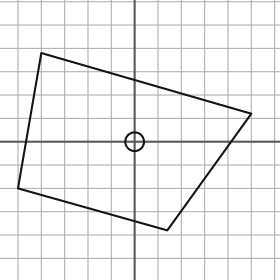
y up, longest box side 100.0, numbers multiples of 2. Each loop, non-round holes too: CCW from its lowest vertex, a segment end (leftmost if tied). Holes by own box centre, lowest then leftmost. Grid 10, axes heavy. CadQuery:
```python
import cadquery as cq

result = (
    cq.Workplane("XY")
    .moveTo(14.0, -38.0)
    .lineTo(50.0, 12.0)
    .lineTo(-40.0, 38.0)
    .lineTo(-50.0, -20.0)
    .close()
    .moveTo(0.0, 0.0)
    .circle(4.0)
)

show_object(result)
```